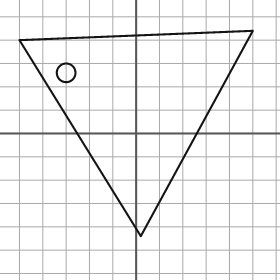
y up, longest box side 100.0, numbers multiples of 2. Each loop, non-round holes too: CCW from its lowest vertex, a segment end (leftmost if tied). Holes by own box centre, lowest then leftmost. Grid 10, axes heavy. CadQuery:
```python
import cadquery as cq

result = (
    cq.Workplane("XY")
    .moveTo(2.0, -44.0)
    .lineTo(50.0, 44.0)
    .lineTo(-50.0, 40.0)
    .close()
    .moveTo(-30.0, 26.0)
    .circle(4.0)
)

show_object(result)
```